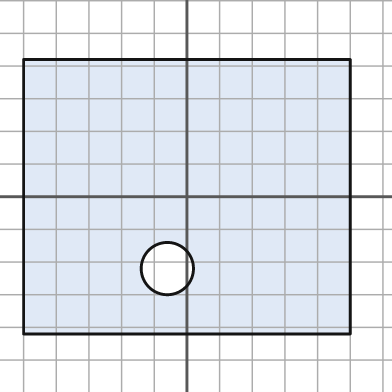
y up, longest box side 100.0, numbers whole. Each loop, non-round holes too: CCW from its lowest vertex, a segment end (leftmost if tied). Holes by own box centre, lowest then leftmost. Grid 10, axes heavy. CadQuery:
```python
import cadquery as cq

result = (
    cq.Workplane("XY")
    .moveTo(-50.0, -42.0)
    .lineTo(50.0, -42.0)
    .lineTo(50.0, 42.0)
    .lineTo(-50.0, 42.0)
    .close()
    .moveTo(-6.0, -22.0)
    .circle(8.0)
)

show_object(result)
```